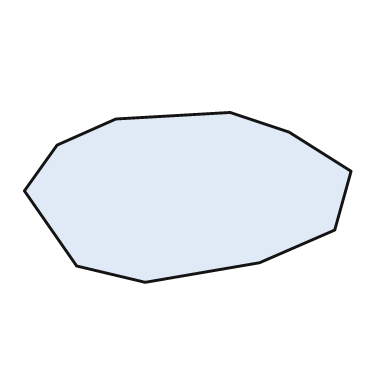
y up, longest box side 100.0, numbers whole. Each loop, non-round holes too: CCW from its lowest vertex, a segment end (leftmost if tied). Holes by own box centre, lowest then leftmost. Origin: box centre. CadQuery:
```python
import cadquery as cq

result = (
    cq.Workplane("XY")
    .moveTo(-13.0, -26.0)
    .lineTo(22.0, -20.0)
    .lineTo(45.0, -10.0)
    .lineTo(50.0, 8.0)
    .lineTo(31.0, 20.0)
    .lineTo(13.0, 26.0)
    .lineTo(-22.0, 24.0)
    .lineTo(-40.0, 16.0)
    .lineTo(-50.0, 2.0)
    .lineTo(-34.0, -21.0)
    .close()
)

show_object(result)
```